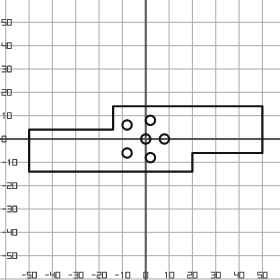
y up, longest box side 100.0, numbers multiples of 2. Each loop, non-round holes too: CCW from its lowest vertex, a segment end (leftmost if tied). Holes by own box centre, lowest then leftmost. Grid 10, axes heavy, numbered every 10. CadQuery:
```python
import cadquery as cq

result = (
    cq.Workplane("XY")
    .moveTo(-50.0, -14.0)
    .lineTo(20.0, -14.0)
    .lineTo(20.0, -6.0)
    .lineTo(50.0, -6.0)
    .lineTo(50.0, 14.0)
    .lineTo(-14.0, 14.0)
    .lineTo(-14.0, 4.0)
    .lineTo(-50.0, 4.0)
    .close()
    .moveTo(2.0, -8.0)
    .circle(2.0)
    .moveTo(-8.0, -6.0)
    .circle(2.0)
    .moveTo(0.0, 0.0)
    .circle(2.0)
    .moveTo(8.0, 0.0)
    .circle(2.0)
    .moveTo(-8.0, 6.0)
    .circle(2.0)
    .moveTo(2.0, 8.0)
    .circle(2.0)
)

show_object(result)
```